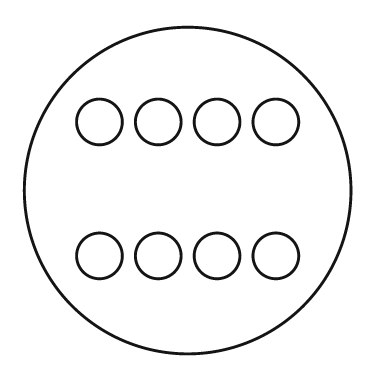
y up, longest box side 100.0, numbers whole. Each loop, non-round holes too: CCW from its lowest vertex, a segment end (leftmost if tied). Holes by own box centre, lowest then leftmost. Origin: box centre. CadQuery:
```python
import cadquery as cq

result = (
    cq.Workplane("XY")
    .moveTo(0.0, 0.0)
    .circle(50.0)
    .moveTo(-27.0, -20.0)
    .circle(7.0)
    .moveTo(-9.0, -20.0)
    .circle(7.0)
    .moveTo(9.0, -20.0)
    .circle(7.0)
    .moveTo(27.0, -20.0)
    .circle(7.0)
    .moveTo(-27.0, 21.0)
    .circle(7.0)
    .moveTo(-9.0, 21.0)
    .circle(7.0)
    .moveTo(9.0, 21.0)
    .circle(7.0)
    .moveTo(27.0, 21.0)
    .circle(7.0)
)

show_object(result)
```